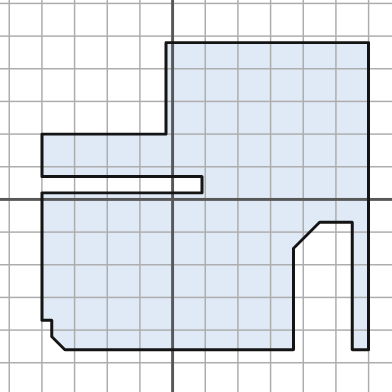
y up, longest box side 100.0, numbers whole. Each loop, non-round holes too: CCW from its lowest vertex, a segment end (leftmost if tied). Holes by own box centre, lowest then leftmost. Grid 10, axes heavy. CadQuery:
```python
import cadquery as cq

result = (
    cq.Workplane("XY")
    .moveTo(-33.0, -46.0)
    .lineTo(37.0, -46.0)
    .lineTo(37.0, -15.0)
    .lineTo(45.0, -7.0)
    .lineTo(55.0, -7.0)
    .lineTo(55.0, -46.0)
    .lineTo(60.0, -46.0)
    .lineTo(60.0, 48.0)
    .lineTo(-2.0, 48.0)
    .lineTo(-2.0, 20.0)
    .lineTo(-40.0, 20.0)
    .lineTo(-40.0, 7.0)
    .lineTo(9.0, 7.0)
    .lineTo(9.0, 2.0)
    .lineTo(-40.0, 2.0)
    .lineTo(-40.0, -37.0)
    .lineTo(-37.0, -37.0)
    .lineTo(-37.0, -42.0)
    .close()
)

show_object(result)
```